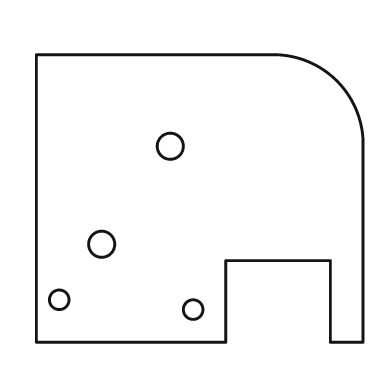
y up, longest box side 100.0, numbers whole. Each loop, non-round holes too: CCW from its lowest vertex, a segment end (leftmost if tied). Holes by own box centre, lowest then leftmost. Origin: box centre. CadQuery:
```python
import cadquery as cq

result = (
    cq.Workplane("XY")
    .moveTo(-50.0, -44.0)
    .lineTo(8.0, -44.0)
    .lineTo(8.0, -19.0)
    .lineTo(40.0, -19.0)
    .lineTo(40.0, -44.0)
    .lineTo(50.0, -44.0)
    .lineTo(50.0, 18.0)
    .threePointArc((42.0, 36.0), (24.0, 44.0))
    .lineTo(-50.0, 44.0)
    .close()
    .moveTo(-2.0, -34.0)
    .circle(3.0)
    .moveTo(-43.0, -31.0)
    .circle(3.0)
    .moveTo(-30.0, -14.0)
    .circle(4.0)
    .moveTo(-9.0, 16.0)
    .circle(4.0)
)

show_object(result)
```